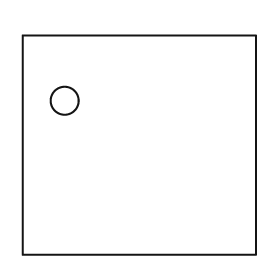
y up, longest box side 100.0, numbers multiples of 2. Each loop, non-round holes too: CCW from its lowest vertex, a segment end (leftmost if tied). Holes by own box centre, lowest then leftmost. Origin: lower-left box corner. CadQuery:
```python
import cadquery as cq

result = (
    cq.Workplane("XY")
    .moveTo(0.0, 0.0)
    .lineTo(100.0, 0.0)
    .lineTo(100.0, 94.0)
    .lineTo(0.0, 94.0)
    .close()
    .moveTo(18.0, 66.0)
    .circle(6.0)
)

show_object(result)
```